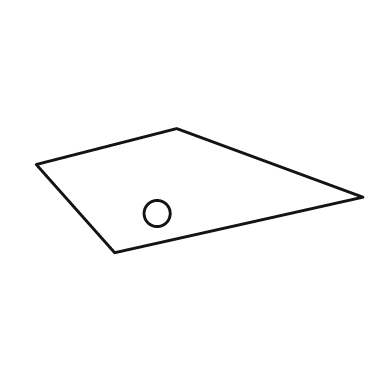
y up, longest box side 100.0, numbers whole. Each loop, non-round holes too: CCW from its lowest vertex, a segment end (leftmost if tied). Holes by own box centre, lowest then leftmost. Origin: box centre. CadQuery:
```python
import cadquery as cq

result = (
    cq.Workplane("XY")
    .moveTo(-26.0, -19.0)
    .lineTo(50.0, -2.0)
    .lineTo(-7.0, 19.0)
    .lineTo(-50.0, 8.0)
    .close()
    .moveTo(-13.0, -7.0)
    .circle(4.0)
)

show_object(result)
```